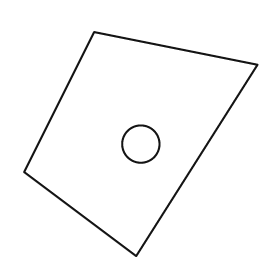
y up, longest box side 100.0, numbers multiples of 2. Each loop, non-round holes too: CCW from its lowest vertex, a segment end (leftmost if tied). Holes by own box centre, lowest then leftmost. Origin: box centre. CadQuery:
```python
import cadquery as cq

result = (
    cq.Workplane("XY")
    .moveTo(-2.0, -48.0)
    .lineTo(50.0, 34.0)
    .lineTo(-20.0, 48.0)
    .lineTo(-50.0, -12.0)
    .close()
    .moveTo(0.0, 0.0)
    .circle(8.0)
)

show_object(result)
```